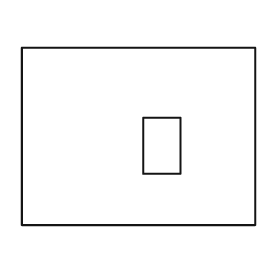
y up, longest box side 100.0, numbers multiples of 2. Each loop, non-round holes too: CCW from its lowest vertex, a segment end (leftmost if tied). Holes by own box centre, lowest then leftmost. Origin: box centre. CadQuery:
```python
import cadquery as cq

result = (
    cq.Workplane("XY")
    .moveTo(-50.0, -38.0)
    .lineTo(50.0, -38.0)
    .lineTo(50.0, 38.0)
    .lineTo(-50.0, 38.0)
    .close()
    .moveTo(2.0, -16.0)
    .lineTo(18.0, -16.0)
    .lineTo(18.0, 8.0)
    .lineTo(2.0, 8.0)
    .close()
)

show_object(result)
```